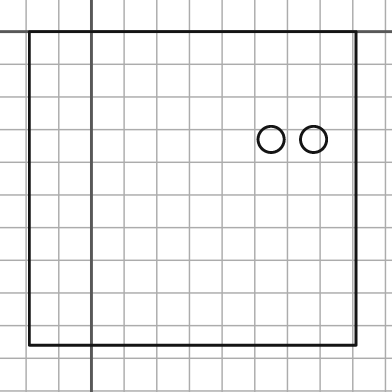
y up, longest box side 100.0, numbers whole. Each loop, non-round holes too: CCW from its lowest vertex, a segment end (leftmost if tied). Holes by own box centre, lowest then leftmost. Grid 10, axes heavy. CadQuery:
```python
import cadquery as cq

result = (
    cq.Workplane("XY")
    .moveTo(-19.0, -96.0)
    .lineTo(81.0, -96.0)
    .lineTo(81.0, 0.0)
    .lineTo(-19.0, 0.0)
    .close()
    .moveTo(55.0, -33.0)
    .circle(4.0)
    .moveTo(68.0, -33.0)
    .circle(4.0)
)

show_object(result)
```